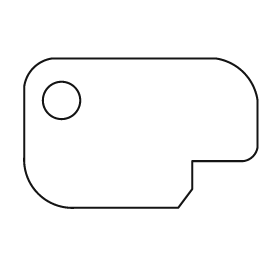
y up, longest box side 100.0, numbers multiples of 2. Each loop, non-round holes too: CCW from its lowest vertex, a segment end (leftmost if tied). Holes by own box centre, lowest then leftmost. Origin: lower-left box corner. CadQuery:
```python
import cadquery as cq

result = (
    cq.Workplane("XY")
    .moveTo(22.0, 0.0)
    .lineTo(66.0, 0.0)
    .lineTo(72.0, 8.0)
    .lineTo(72.0, 20.0)
    .lineTo(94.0, 20.0)
    .threePointArc((98.0, 22.0), (100.0, 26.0))
    .lineTo(100.0, 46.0)
    .threePointArc((94.0, 58.0), (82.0, 64.0))
    .lineTo(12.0, 64.0)
    .threePointArc((4.0, 60.0), (0.0, 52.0))
    .lineTo(0.0, 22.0)
    .threePointArc((6.0, 6.0), (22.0, 0.0))
    .close()
    .moveTo(16.0, 46.0)
    .circle(8.0)
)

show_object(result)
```